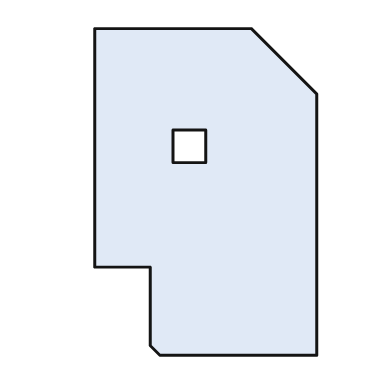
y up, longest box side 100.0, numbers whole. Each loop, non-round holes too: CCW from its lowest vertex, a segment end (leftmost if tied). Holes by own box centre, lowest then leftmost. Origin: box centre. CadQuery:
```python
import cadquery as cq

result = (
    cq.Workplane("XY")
    .moveTo(-14.0, -50.0)
    .lineTo(34.0, -50.0)
    .lineTo(34.0, 30.0)
    .lineTo(14.0, 50.0)
    .lineTo(-34.0, 50.0)
    .lineTo(-34.0, -23.0)
    .lineTo(-17.0, -23.0)
    .lineTo(-17.0, -47.0)
    .close()
    .moveTo(-10.0, 9.0)
    .lineTo(0.0, 9.0)
    .lineTo(0.0, 19.0)
    .lineTo(-10.0, 19.0)
    .close()
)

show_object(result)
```